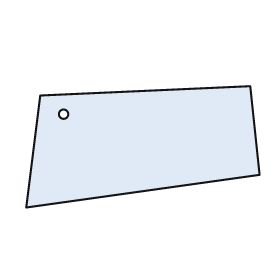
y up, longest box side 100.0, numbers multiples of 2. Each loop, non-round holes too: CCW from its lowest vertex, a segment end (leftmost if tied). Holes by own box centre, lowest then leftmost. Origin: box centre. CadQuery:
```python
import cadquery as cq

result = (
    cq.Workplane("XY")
    .moveTo(-50.0, -26.0)
    .lineTo(50.0, -12.0)
    .lineTo(46.0, 26.0)
    .lineTo(-44.0, 22.0)
    .close()
    .moveTo(-34.0, 14.0)
    .circle(2.0)
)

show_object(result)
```